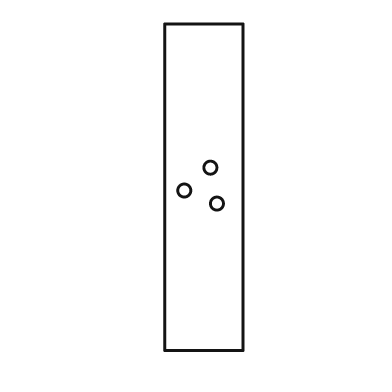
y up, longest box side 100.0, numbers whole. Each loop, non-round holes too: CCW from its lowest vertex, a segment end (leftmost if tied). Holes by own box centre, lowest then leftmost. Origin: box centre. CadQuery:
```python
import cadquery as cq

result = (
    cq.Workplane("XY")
    .moveTo(-12.0, -50.0)
    .lineTo(12.0, -50.0)
    .lineTo(12.0, 50.0)
    .lineTo(-12.0, 50.0)
    .close()
    .moveTo(4.0, -5.0)
    .circle(2.0)
    .moveTo(-6.0, -1.0)
    .circle(2.0)
    .moveTo(2.0, 6.0)
    .circle(2.0)
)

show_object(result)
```